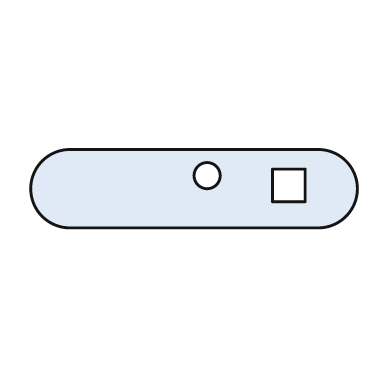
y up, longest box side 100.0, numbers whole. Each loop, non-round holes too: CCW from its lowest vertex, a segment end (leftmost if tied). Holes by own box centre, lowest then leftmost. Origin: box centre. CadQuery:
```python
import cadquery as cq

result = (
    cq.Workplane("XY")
    .moveTo(-38.0, -12.0)
    .lineTo(38.0, -12.0)
    .threePointArc((50.0, 0.0), (38.0, 12.0))
    .lineTo(-38.0, 12.0)
    .threePointArc((-50.0, 0.0), (-38.0, -12.0))
    .close()
    .moveTo(24.0, -4.0)
    .lineTo(34.0, -4.0)
    .lineTo(34.0, 6.0)
    .lineTo(24.0, 6.0)
    .close()
    .moveTo(4.0, 4.0)
    .circle(4.0)
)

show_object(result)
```